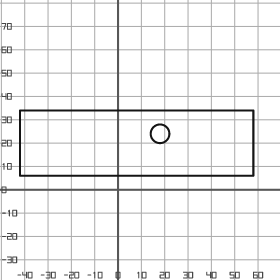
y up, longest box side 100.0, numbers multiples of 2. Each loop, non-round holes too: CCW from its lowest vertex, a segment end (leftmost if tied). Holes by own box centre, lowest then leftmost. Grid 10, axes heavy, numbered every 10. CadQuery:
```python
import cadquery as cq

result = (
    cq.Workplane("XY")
    .moveTo(-42.0, 6.0)
    .lineTo(58.0, 6.0)
    .lineTo(58.0, 34.0)
    .lineTo(-42.0, 34.0)
    .close()
    .moveTo(18.0, 24.0)
    .circle(4.0)
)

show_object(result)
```